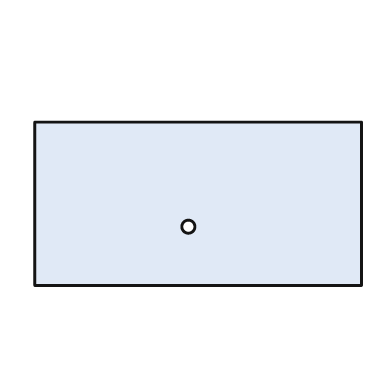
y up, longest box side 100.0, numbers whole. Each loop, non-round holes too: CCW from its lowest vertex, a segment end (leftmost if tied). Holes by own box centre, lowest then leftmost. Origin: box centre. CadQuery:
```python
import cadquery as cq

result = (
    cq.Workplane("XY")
    .moveTo(-50.0, -25.0)
    .lineTo(50.0, -25.0)
    .lineTo(50.0, 25.0)
    .lineTo(-50.0, 25.0)
    .close()
    .moveTo(-3.0, -7.0)
    .circle(2.0)
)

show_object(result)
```